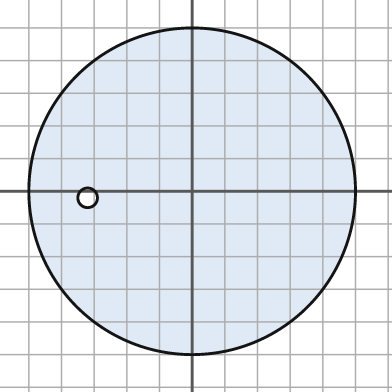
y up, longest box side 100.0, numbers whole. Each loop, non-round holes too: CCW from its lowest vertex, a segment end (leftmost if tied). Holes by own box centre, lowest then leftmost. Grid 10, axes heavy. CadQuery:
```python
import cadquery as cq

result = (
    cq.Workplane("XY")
    .moveTo(0.0, 0.0)
    .circle(50.0)
    .moveTo(-32.0, -2.0)
    .circle(3.0)
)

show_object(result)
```